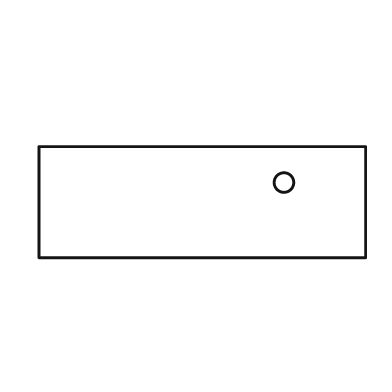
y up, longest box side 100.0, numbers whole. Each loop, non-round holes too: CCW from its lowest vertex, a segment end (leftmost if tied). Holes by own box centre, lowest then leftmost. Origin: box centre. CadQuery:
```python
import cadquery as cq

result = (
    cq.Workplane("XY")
    .moveTo(-50.0, -17.0)
    .lineTo(50.0, -17.0)
    .lineTo(50.0, 17.0)
    .lineTo(-50.0, 17.0)
    .close()
    .moveTo(25.0, 6.0)
    .circle(3.0)
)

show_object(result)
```